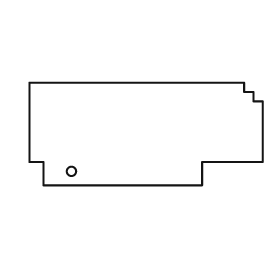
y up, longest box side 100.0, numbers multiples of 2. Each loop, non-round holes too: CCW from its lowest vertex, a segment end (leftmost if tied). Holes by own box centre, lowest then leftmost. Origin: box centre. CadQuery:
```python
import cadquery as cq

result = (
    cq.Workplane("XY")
    .moveTo(-44.0, -22.0)
    .lineTo(24.0, -22.0)
    .lineTo(24.0, -12.0)
    .lineTo(50.0, -12.0)
    .lineTo(50.0, 14.0)
    .lineTo(46.0, 14.0)
    .lineTo(46.0, 18.0)
    .lineTo(42.0, 18.0)
    .lineTo(42.0, 22.0)
    .lineTo(-50.0, 22.0)
    .lineTo(-50.0, -12.0)
    .lineTo(-44.0, -12.0)
    .close()
    .moveTo(-32.0, -16.0)
    .circle(2.0)
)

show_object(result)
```